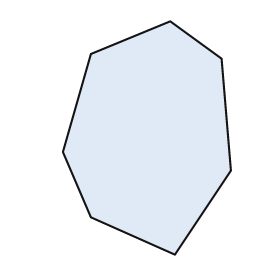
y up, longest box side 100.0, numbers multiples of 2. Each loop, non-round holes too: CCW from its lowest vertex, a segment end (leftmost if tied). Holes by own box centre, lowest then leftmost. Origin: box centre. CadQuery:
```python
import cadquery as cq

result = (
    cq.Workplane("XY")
    .moveTo(12.0, -50.0)
    .lineTo(36.0, -14.0)
    .lineTo(32.0, 34.0)
    .lineTo(10.0, 50.0)
    .lineTo(-24.0, 36.0)
    .lineTo(-36.0, -6.0)
    .lineTo(-24.0, -34.0)
    .close()
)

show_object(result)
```